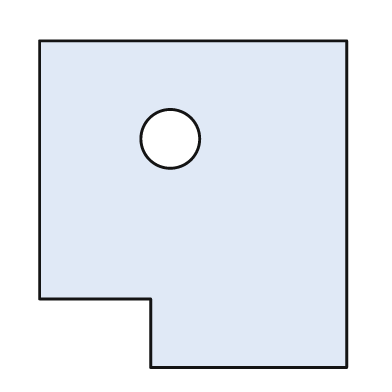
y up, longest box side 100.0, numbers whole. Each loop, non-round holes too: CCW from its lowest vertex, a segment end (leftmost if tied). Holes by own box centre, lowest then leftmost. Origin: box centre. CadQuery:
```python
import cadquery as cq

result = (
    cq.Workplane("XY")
    .moveTo(-13.0, -50.0)
    .lineTo(47.0, -50.0)
    .lineTo(47.0, 50.0)
    .lineTo(-47.0, 50.0)
    .lineTo(-47.0, -29.0)
    .lineTo(-13.0, -29.0)
    .close()
    .moveTo(-7.0, 20.0)
    .circle(9.0)
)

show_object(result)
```